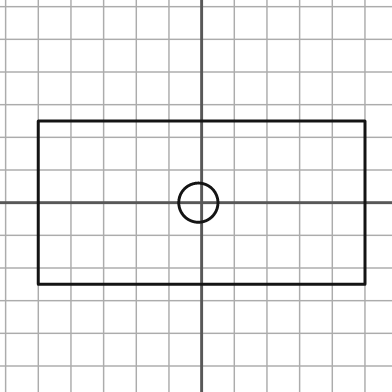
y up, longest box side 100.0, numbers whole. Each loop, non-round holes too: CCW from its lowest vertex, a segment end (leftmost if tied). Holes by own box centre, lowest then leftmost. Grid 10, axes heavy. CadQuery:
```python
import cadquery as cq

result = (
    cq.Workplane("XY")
    .moveTo(-50.0, -25.0)
    .lineTo(50.0, -25.0)
    .lineTo(50.0, 25.0)
    .lineTo(-50.0, 25.0)
    .close()
    .moveTo(-1.0, 0.0)
    .circle(6.0)
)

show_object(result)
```